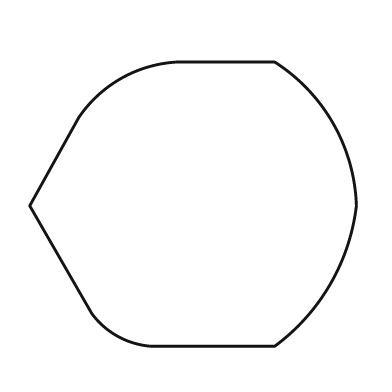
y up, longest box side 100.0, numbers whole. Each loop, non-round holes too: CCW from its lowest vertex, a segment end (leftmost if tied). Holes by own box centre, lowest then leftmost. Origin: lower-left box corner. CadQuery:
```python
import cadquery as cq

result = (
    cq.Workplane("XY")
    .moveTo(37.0, 0.0)
    .lineTo(75.0, 0.0)
    .threePointArc((92.0, 19.0), (100.0, 43.0))
    .threePointArc((93.0, 68.0), (75.0, 87.0))
    .lineTo(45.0, 87.0)
    .threePointArc((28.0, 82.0), (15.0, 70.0))
    .lineTo(0.0, 43.0)
    .lineTo(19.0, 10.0)
    .threePointArc((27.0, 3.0), (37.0, 0.0))
    .close()
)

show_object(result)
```